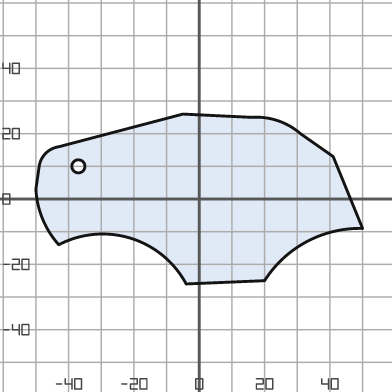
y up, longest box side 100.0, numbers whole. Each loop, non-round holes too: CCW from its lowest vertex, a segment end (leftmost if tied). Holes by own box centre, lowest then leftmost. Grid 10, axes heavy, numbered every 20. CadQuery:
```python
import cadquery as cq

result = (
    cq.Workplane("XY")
    .moveTo(-4.0, -26.0)
    .lineTo(20.0, -25.0)
    .threePointArc((33.0, -13.0), (50.0, -9.0))
    .lineTo(41.0, 13.0)
    .lineTo(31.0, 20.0)
    .threePointArc((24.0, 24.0), (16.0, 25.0))
    .lineTo(-5.0, 26.0)
    .lineTo(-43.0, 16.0)
    .threePointArc((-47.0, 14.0), (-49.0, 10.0))
    .lineTo(-50.0, 3.0)
    .threePointArc((-48.0, -6.0), (-43.0, -14.0))
    .threePointArc((-21.0, -12.0), (-4.0, -26.0))
    .close()
    .moveTo(-37.0, 10.0)
    .circle(2.0)
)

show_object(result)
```